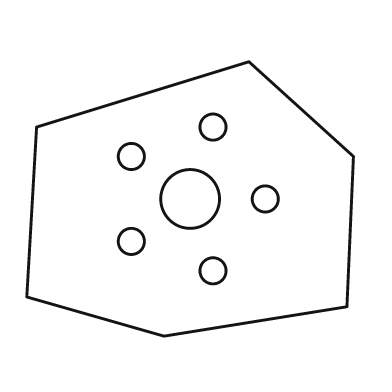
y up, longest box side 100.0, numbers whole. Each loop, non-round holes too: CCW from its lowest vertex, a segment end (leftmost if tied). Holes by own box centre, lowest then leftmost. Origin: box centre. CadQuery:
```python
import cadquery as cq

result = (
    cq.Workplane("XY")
    .moveTo(-8.0, -42.0)
    .lineTo(48.0, -33.0)
    .lineTo(50.0, 13.0)
    .lineTo(18.0, 42.0)
    .lineTo(-47.0, 22.0)
    .lineTo(-50.0, -30.0)
    .close()
    .moveTo(7.0, -22.0)
    .circle(4.0)
    .moveTo(-18.0, -13.0)
    .circle(4.0)
    .moveTo(0.0, 0.0)
    .circle(9.0)
    .moveTo(23.0, 0.0)
    .circle(4.0)
    .moveTo(-18.0, 13.0)
    .circle(4.0)
    .moveTo(7.0, 22.0)
    .circle(4.0)
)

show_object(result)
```